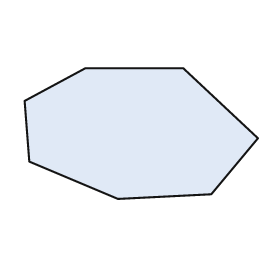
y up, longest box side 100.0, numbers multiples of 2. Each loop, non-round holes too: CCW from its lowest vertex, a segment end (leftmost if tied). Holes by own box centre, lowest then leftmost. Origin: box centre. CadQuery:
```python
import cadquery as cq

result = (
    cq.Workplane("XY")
    .moveTo(-10.0, -28.0)
    .lineTo(30.0, -26.0)
    .lineTo(50.0, -2.0)
    .lineTo(18.0, 28.0)
    .lineTo(-24.0, 28.0)
    .lineTo(-50.0, 14.0)
    .lineTo(-48.0, -12.0)
    .close()
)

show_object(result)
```